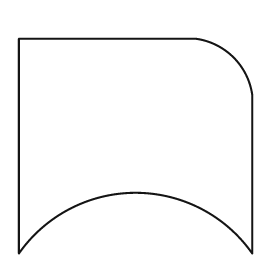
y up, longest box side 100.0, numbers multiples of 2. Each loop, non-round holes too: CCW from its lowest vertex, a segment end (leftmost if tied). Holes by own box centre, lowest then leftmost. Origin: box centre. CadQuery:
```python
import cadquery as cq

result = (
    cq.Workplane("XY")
    .moveTo(-50.0, -46.0)
    .threePointArc((0.0, -20.0), (50.0, -46.0))
    .lineTo(50.0, 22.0)
    .threePointArc((42.0, 38.0), (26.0, 46.0))
    .lineTo(-50.0, 46.0)
    .close()
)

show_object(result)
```